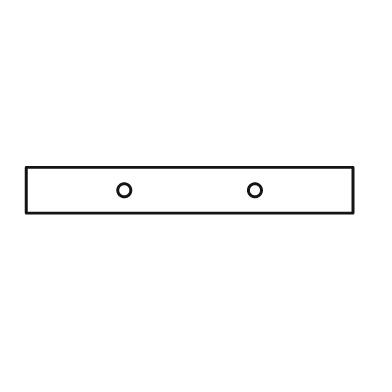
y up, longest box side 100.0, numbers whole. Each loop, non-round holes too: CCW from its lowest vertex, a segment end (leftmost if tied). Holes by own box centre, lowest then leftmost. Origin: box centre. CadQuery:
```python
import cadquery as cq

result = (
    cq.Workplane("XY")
    .moveTo(-50.0, -7.0)
    .lineTo(50.0, -7.0)
    .lineTo(50.0, 7.0)
    .lineTo(-50.0, 7.0)
    .close()
    .moveTo(-20.0, 0.0)
    .circle(2.0)
    .moveTo(20.0, 0.0)
    .circle(2.0)
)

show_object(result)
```